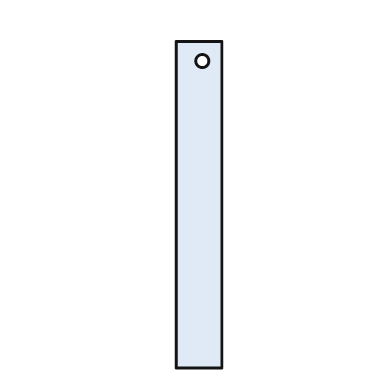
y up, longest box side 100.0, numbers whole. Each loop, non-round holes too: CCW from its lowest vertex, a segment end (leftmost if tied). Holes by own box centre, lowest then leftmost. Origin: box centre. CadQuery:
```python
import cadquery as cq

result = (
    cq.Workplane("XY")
    .moveTo(-7.0, -50.0)
    .lineTo(7.0, -50.0)
    .lineTo(7.0, 50.0)
    .lineTo(-7.0, 50.0)
    .close()
    .moveTo(1.0, 44.0)
    .circle(2.0)
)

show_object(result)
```